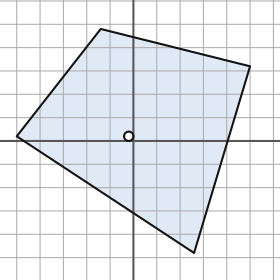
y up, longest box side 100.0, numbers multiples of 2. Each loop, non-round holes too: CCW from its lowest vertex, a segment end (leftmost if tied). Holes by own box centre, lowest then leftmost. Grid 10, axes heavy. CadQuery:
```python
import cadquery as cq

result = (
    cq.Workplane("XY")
    .moveTo(26.0, -48.0)
    .lineTo(50.0, 32.0)
    .lineTo(-14.0, 48.0)
    .lineTo(-50.0, 2.0)
    .close()
    .moveTo(-2.0, 2.0)
    .circle(2.0)
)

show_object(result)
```